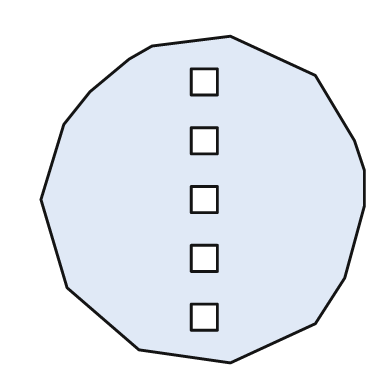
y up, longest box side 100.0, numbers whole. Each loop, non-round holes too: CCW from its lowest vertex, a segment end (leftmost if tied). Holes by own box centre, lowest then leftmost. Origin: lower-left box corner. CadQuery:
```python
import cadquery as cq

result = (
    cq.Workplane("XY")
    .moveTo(58.0, 0.0)
    .lineTo(84.0, 12.0)
    .lineTo(93.0, 26.0)
    .lineTo(99.0, 48.0)
    .lineTo(99.0, 59.0)
    .lineTo(96.0, 68.0)
    .lineTo(84.0, 88.0)
    .lineTo(58.0, 100.0)
    .lineTo(34.0, 97.0)
    .lineTo(27.0, 93.0)
    .lineTo(15.0, 83.0)
    .lineTo(7.0, 73.0)
    .lineTo(0.0, 50.0)
    .lineTo(8.0, 23.0)
    .lineTo(30.0, 4.0)
    .close()
    .moveTo(46.0, 10.0)
    .lineTo(54.0, 10.0)
    .lineTo(54.0, 18.0)
    .lineTo(46.0, 18.0)
    .close()
    .moveTo(46.0, 28.0)
    .lineTo(54.0, 28.0)
    .lineTo(54.0, 36.0)
    .lineTo(46.0, 36.0)
    .close()
    .moveTo(46.0, 46.0)
    .lineTo(54.0, 46.0)
    .lineTo(54.0, 54.0)
    .lineTo(46.0, 54.0)
    .close()
    .moveTo(46.0, 64.0)
    .lineTo(54.0, 64.0)
    .lineTo(54.0, 72.0)
    .lineTo(46.0, 72.0)
    .close()
    .moveTo(46.0, 82.0)
    .lineTo(54.0, 82.0)
    .lineTo(54.0, 90.0)
    .lineTo(46.0, 90.0)
    .close()
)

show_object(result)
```